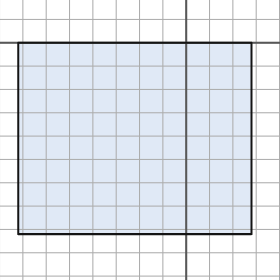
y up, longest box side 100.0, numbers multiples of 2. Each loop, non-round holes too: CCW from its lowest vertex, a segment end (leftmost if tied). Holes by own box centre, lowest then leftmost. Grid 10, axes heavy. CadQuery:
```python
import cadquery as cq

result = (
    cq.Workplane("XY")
    .moveTo(-72.0, -82.0)
    .lineTo(28.0, -82.0)
    .lineTo(28.0, 0.0)
    .lineTo(-72.0, 0.0)
    .close()
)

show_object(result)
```